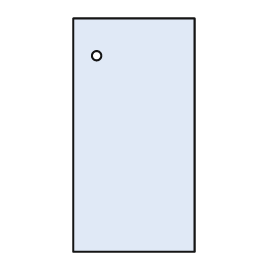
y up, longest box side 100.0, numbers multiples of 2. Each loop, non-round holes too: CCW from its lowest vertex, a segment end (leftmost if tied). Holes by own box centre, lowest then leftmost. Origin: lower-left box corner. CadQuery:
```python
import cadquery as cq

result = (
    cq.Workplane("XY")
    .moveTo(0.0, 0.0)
    .lineTo(52.0, 0.0)
    .lineTo(52.0, 100.0)
    .lineTo(0.0, 100.0)
    .close()
    .moveTo(10.0, 84.0)
    .circle(2.0)
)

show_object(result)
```